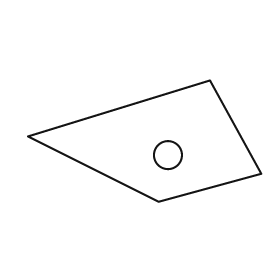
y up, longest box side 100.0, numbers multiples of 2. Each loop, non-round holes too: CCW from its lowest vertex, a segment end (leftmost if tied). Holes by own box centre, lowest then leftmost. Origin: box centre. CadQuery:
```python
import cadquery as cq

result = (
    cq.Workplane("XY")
    .moveTo(6.0, -26.0)
    .lineTo(50.0, -14.0)
    .lineTo(28.0, 26.0)
    .lineTo(-50.0, 2.0)
    .close()
    .moveTo(10.0, -6.0)
    .circle(6.0)
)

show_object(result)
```